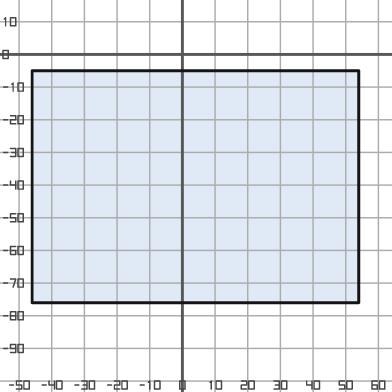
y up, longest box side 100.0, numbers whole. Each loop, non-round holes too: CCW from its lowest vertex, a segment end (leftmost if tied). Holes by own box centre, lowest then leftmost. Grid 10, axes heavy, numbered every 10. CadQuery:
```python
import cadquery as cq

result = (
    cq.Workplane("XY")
    .moveTo(-46.0, -76.0)
    .lineTo(54.0, -76.0)
    .lineTo(54.0, -5.0)
    .lineTo(-46.0, -5.0)
    .close()
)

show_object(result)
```